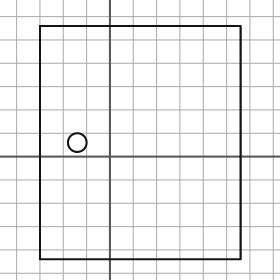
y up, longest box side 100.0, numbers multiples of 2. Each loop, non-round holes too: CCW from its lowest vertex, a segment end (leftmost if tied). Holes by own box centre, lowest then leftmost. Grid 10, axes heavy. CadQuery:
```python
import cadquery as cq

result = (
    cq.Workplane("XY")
    .moveTo(-30.0, -44.0)
    .lineTo(56.0, -44.0)
    .lineTo(56.0, 56.0)
    .lineTo(-30.0, 56.0)
    .close()
    .moveTo(-14.0, 6.0)
    .circle(4.0)
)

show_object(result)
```